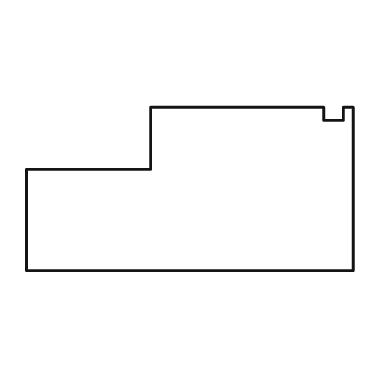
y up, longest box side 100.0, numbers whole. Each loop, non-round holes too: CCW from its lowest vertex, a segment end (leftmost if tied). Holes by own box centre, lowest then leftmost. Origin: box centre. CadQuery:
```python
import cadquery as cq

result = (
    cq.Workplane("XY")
    .moveTo(-50.0, -25.0)
    .lineTo(50.0, -25.0)
    .lineTo(50.0, 25.0)
    .lineTo(47.0, 25.0)
    .lineTo(47.0, 21.0)
    .lineTo(41.0, 21.0)
    .lineTo(41.0, 25.0)
    .lineTo(-12.0, 25.0)
    .lineTo(-12.0, 6.0)
    .lineTo(-50.0, 6.0)
    .close()
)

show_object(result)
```